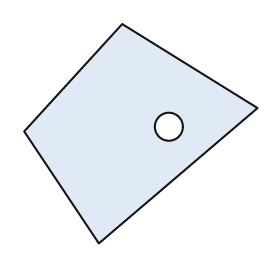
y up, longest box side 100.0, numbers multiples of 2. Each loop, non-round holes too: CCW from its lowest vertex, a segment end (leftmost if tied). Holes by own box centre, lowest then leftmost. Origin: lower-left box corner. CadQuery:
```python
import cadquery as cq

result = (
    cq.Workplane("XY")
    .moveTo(32.0, 0.0)
    .lineTo(100.0, 58.0)
    .lineTo(42.0, 94.0)
    .lineTo(0.0, 48.0)
    .close()
    .moveTo(62.0, 50.0)
    .circle(6.0)
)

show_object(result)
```